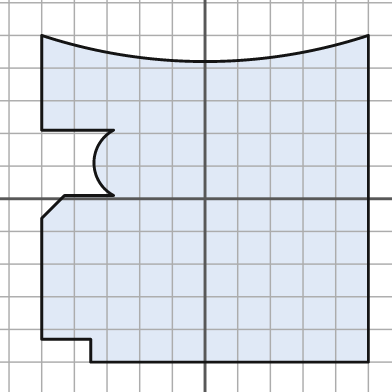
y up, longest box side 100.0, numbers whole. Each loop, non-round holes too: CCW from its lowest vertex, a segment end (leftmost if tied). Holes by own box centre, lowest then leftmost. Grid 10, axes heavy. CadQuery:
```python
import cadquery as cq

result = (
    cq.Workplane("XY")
    .moveTo(-35.0, -50.0)
    .lineTo(50.0, -50.0)
    .lineTo(50.0, 50.0)
    .threePointArc((0.0, 42.0), (-50.0, 50.0))
    .lineTo(-50.0, 21.0)
    .lineTo(-28.0, 21.0)
    .threePointArc((-34.0, 11.0), (-28.0, 1.0))
    .lineTo(-43.0, 1.0)
    .lineTo(-50.0, -6.0)
    .lineTo(-50.0, -43.0)
    .lineTo(-35.0, -43.0)
    .close()
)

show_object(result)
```